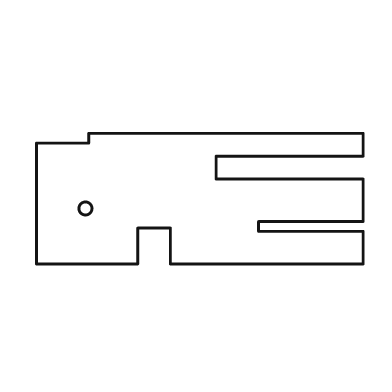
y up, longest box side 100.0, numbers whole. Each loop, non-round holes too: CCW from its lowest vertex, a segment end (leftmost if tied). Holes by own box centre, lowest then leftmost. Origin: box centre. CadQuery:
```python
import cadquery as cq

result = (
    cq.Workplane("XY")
    .moveTo(-50.0, -20.0)
    .lineTo(-19.0, -20.0)
    .lineTo(-19.0, -9.0)
    .lineTo(-9.0, -9.0)
    .lineTo(-9.0, -20.0)
    .lineTo(50.0, -20.0)
    .lineTo(50.0, -10.0)
    .lineTo(18.0, -10.0)
    .lineTo(18.0, -7.0)
    .lineTo(50.0, -7.0)
    .lineTo(50.0, 6.0)
    .lineTo(5.0, 6.0)
    .lineTo(5.0, 13.0)
    .lineTo(50.0, 13.0)
    .lineTo(50.0, 20.0)
    .lineTo(-34.0, 20.0)
    .lineTo(-34.0, 17.0)
    .lineTo(-50.0, 17.0)
    .close()
    .moveTo(-35.0, -3.0)
    .circle(2.0)
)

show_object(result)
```